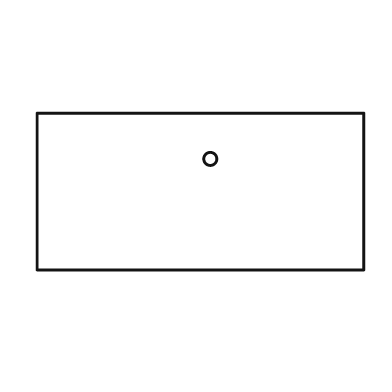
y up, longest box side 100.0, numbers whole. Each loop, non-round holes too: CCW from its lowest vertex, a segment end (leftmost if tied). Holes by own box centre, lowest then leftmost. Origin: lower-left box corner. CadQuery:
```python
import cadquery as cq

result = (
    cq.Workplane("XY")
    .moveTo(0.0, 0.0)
    .lineTo(100.0, 0.0)
    .lineTo(100.0, 48.0)
    .lineTo(0.0, 48.0)
    .close()
    .moveTo(53.0, 34.0)
    .circle(2.0)
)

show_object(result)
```